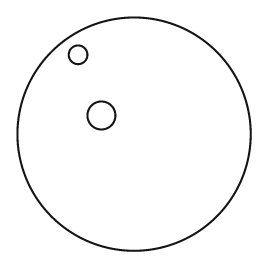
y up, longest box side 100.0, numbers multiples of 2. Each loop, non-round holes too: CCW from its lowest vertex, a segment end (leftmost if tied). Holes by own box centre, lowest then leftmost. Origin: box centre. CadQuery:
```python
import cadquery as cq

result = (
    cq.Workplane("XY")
    .moveTo(0.0, 0.0)
    .circle(50.0)
    .moveTo(-14.0, 8.0)
    .circle(6.0)
    .moveTo(-24.0, 34.0)
    .circle(4.0)
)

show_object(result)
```